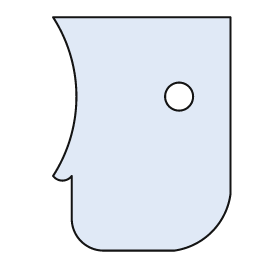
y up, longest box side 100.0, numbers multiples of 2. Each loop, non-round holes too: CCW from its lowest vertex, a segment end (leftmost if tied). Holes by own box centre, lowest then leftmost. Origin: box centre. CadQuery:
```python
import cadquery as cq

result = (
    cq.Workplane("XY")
    .moveTo(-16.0, -50.0)
    .lineTo(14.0, -50.0)
    .threePointArc((30.0, -42.0), (38.0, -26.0))
    .lineTo(38.0, 50.0)
    .lineTo(-38.0, 50.0)
    .threePointArc((-28.0, 16.0), (-38.0, -18.0))
    .threePointArc((-34.0, -20.0), (-30.0, -18.0))
    .lineTo(-30.0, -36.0)
    .threePointArc((-26.0, -46.0), (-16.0, -50.0))
    .close()
    .moveTo(16.0, 16.0)
    .circle(6.0)
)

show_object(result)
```